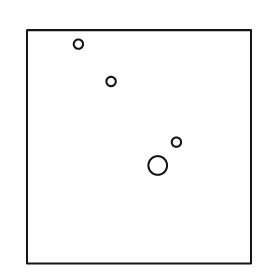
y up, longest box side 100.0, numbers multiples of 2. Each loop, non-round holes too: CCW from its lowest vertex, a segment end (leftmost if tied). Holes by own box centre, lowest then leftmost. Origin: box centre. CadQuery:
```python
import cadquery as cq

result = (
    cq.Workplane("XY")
    .moveTo(-48.0, -50.0)
    .lineTo(48.0, -50.0)
    .lineTo(48.0, 50.0)
    .lineTo(-48.0, 50.0)
    .close()
    .moveTo(8.0, -8.0)
    .circle(4.0)
    .moveTo(16.0, 2.0)
    .circle(2.0)
    .moveTo(-12.0, 28.0)
    .circle(2.0)
    .moveTo(-26.0, 44.0)
    .circle(2.0)
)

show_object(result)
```